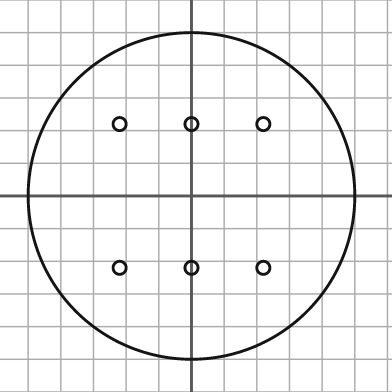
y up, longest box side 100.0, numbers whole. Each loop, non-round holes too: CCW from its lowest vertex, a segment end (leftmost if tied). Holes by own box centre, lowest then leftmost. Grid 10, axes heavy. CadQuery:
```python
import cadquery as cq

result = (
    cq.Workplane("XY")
    .moveTo(0.0, 0.0)
    .circle(50.0)
    .moveTo(-22.0, -22.0)
    .circle(2.0)
    .moveTo(0.0, -22.0)
    .circle(2.0)
    .moveTo(22.0, -22.0)
    .circle(2.0)
    .moveTo(-22.0, 22.0)
    .circle(2.0)
    .moveTo(0.0, 22.0)
    .circle(2.0)
    .moveTo(22.0, 22.0)
    .circle(2.0)
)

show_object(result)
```